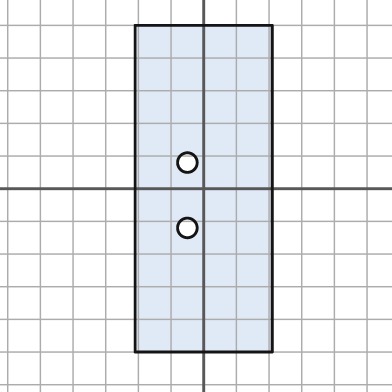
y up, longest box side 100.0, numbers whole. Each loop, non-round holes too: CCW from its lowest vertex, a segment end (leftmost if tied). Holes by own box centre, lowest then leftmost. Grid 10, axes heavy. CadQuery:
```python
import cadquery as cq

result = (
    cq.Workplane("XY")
    .moveTo(-21.0, -50.0)
    .lineTo(21.0, -50.0)
    .lineTo(21.0, 50.0)
    .lineTo(-21.0, 50.0)
    .close()
    .moveTo(-5.0, -12.0)
    .circle(3.0)
    .moveTo(-5.0, 8.0)
    .circle(3.0)
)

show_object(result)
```